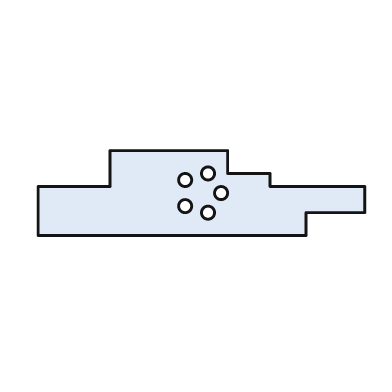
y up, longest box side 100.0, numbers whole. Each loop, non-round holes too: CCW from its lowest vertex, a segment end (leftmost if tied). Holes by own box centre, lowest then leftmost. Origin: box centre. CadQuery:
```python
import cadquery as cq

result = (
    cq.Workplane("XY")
    .moveTo(-50.0, -13.0)
    .lineTo(32.0, -13.0)
    .lineTo(32.0, -6.0)
    .lineTo(50.0, -6.0)
    .lineTo(50.0, 2.0)
    .lineTo(21.0, 2.0)
    .lineTo(21.0, 6.0)
    .lineTo(8.0, 6.0)
    .lineTo(8.0, 13.0)
    .lineTo(-28.0, 13.0)
    .lineTo(-28.0, 2.0)
    .lineTo(-50.0, 2.0)
    .close()
    .moveTo(2.0, -6.0)
    .circle(2.0)
    .moveTo(-5.0, -4.0)
    .circle(2.0)
    .moveTo(6.0, 0.0)
    .circle(2.0)
    .moveTo(-5.0, 4.0)
    .circle(2.0)
    .moveTo(2.0, 6.0)
    .circle(2.0)
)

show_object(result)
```